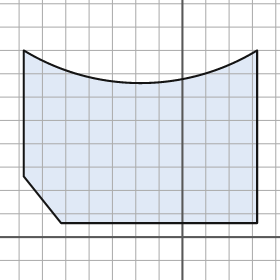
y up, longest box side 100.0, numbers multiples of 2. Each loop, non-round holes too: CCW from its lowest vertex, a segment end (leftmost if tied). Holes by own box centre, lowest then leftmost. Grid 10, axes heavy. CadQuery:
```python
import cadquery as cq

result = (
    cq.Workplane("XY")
    .moveTo(-52.0, 6.0)
    .lineTo(32.0, 6.0)
    .lineTo(32.0, 80.0)
    .threePointArc((-18.0, 66.0), (-68.0, 80.0))
    .lineTo(-68.0, 26.0)
    .close()
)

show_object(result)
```